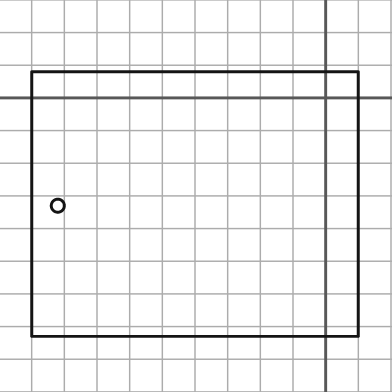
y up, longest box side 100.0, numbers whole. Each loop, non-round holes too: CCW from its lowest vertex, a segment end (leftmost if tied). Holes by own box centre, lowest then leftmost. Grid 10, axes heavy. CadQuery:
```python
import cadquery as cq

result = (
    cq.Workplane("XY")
    .moveTo(-90.0, -73.0)
    .lineTo(10.0, -73.0)
    .lineTo(10.0, 8.0)
    .lineTo(-90.0, 8.0)
    .close()
    .moveTo(-82.0, -33.0)
    .circle(2.0)
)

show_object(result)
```